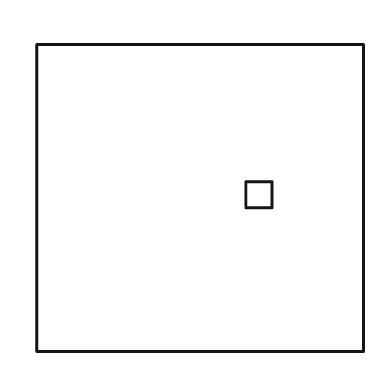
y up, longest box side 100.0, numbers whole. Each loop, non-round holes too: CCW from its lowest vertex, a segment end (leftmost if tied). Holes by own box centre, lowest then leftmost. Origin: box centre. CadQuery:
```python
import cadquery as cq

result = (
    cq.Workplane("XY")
    .moveTo(-50.0, -47.0)
    .lineTo(50.0, -47.0)
    .lineTo(50.0, 47.0)
    .lineTo(-50.0, 47.0)
    .close()
    .moveTo(14.0, -3.0)
    .lineTo(22.0, -3.0)
    .lineTo(22.0, 5.0)
    .lineTo(14.0, 5.0)
    .close()
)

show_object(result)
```